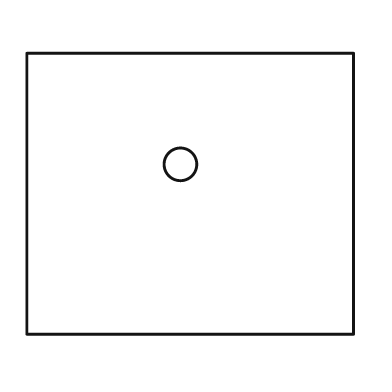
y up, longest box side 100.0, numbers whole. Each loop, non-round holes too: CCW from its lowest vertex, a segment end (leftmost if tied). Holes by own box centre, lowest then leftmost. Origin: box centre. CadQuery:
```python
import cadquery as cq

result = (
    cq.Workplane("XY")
    .moveTo(-50.0, -43.0)
    .lineTo(50.0, -43.0)
    .lineTo(50.0, 43.0)
    .lineTo(-50.0, 43.0)
    .close()
    .moveTo(-3.0, 9.0)
    .circle(5.0)
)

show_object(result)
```